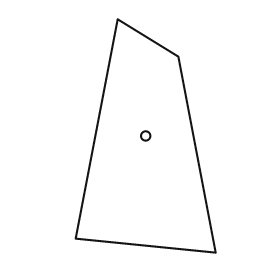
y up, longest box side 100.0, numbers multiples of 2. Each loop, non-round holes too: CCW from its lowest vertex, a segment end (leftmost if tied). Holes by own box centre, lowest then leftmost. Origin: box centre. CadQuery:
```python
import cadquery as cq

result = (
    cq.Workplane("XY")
    .moveTo(30.0, -50.0)
    .lineTo(14.0, 34.0)
    .lineTo(-12.0, 50.0)
    .lineTo(-30.0, -44.0)
    .close()
    .moveTo(0.0, 0.0)
    .circle(2.0)
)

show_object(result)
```